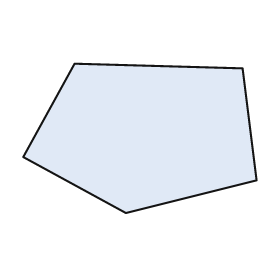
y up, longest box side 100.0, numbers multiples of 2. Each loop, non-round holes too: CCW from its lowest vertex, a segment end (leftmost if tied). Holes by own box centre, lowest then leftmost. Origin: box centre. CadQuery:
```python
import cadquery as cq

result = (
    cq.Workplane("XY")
    .moveTo(-6.0, -32.0)
    .lineTo(50.0, -18.0)
    .lineTo(44.0, 30.0)
    .lineTo(-28.0, 32.0)
    .lineTo(-50.0, -8.0)
    .close()
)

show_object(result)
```